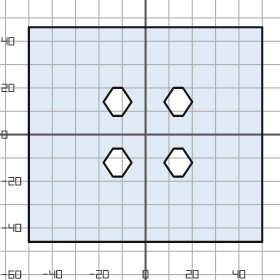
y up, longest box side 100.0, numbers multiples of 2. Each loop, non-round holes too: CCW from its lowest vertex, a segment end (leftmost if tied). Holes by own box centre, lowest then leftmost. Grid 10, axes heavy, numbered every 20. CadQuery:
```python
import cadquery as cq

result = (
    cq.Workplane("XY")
    .moveTo(-50.0, -46.0)
    .lineTo(50.0, -46.0)
    .lineTo(50.0, 46.0)
    .lineTo(-50.0, 46.0)
    .close()
    .moveTo(-14.0, -18.0)
    .lineTo(-10.0, -18.0)
    .lineTo(-6.0, -12.0)
    .lineTo(-10.0, -6.0)
    .lineTo(-14.0, -6.0)
    .lineTo(-18.0, -12.0)
    .close()
    .moveTo(12.0, -18.0)
    .lineTo(16.0, -18.0)
    .lineTo(20.0, -12.0)
    .lineTo(16.0, -6.0)
    .lineTo(12.0, -6.0)
    .lineTo(8.0, -12.0)
    .close()
    .moveTo(-14.0, 8.0)
    .lineTo(-10.0, 8.0)
    .lineTo(-6.0, 14.0)
    .lineTo(-10.0, 20.0)
    .lineTo(-14.0, 20.0)
    .lineTo(-18.0, 14.0)
    .close()
    .moveTo(12.0, 8.0)
    .lineTo(16.0, 8.0)
    .lineTo(20.0, 14.0)
    .lineTo(16.0, 20.0)
    .lineTo(12.0, 20.0)
    .lineTo(8.0, 14.0)
    .close()
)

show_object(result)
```